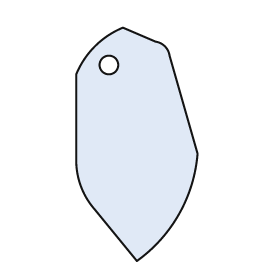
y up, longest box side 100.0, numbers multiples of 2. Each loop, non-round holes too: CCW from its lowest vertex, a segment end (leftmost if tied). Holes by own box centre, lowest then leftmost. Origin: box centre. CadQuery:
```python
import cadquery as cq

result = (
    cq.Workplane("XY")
    .moveTo(0.0, -50.0)
    .threePointArc((18.0, -30.0), (26.0, -4.0))
    .lineTo(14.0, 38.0)
    .threePointArc((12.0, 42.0), (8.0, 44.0))
    .lineTo(-6.0, 50.0)
    .threePointArc((-18.0, 42.0), (-26.0, 30.0))
    .lineTo(-26.0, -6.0)
    .threePointArc((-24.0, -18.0), (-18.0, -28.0))
    .close()
    .moveTo(-12.0, 34.0)
    .circle(4.0)
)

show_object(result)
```